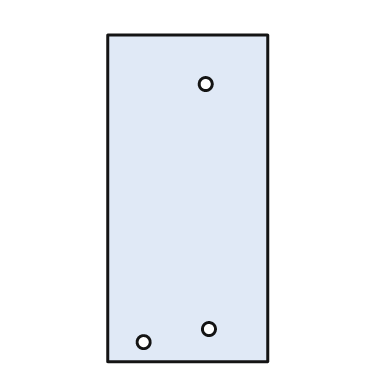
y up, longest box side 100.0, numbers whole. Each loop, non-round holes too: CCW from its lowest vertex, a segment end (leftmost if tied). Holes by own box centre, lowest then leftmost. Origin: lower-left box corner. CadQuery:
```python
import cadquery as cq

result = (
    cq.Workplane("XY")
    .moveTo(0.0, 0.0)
    .lineTo(49.0, 0.0)
    .lineTo(49.0, 100.0)
    .lineTo(0.0, 100.0)
    .close()
    .moveTo(11.0, 6.0)
    .circle(2.0)
    .moveTo(31.0, 10.0)
    .circle(2.0)
    .moveTo(30.0, 85.0)
    .circle(2.0)
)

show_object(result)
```